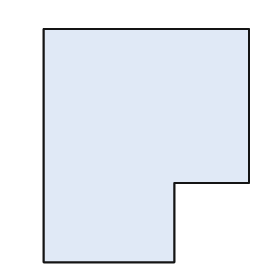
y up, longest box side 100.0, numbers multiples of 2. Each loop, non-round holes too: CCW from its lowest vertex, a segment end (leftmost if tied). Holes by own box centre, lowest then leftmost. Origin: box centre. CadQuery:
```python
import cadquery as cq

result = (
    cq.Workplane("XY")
    .moveTo(-44.0, -50.0)
    .lineTo(12.0, -50.0)
    .lineTo(12.0, -16.0)
    .lineTo(44.0, -16.0)
    .lineTo(44.0, 50.0)
    .lineTo(-44.0, 50.0)
    .close()
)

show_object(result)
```